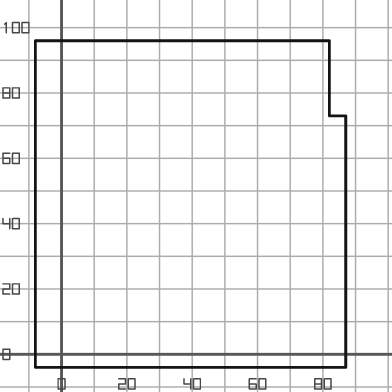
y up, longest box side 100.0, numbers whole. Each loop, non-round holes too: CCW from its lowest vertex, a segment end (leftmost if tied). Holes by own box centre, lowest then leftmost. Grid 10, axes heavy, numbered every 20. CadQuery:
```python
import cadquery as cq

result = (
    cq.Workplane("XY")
    .moveTo(-8.0, -4.0)
    .lineTo(87.0, -4.0)
    .lineTo(87.0, 73.0)
    .lineTo(82.0, 73.0)
    .lineTo(82.0, 96.0)
    .lineTo(-8.0, 96.0)
    .close()
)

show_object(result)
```